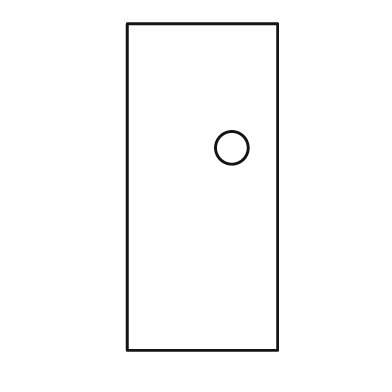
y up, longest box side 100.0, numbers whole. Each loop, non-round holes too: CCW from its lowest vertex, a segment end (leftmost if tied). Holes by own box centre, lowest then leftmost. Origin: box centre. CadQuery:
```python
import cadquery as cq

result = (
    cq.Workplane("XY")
    .moveTo(-23.0, -50.0)
    .lineTo(23.0, -50.0)
    .lineTo(23.0, 50.0)
    .lineTo(-23.0, 50.0)
    .close()
    .moveTo(9.0, 12.0)
    .circle(5.0)
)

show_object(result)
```